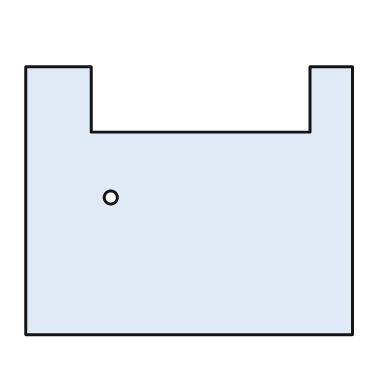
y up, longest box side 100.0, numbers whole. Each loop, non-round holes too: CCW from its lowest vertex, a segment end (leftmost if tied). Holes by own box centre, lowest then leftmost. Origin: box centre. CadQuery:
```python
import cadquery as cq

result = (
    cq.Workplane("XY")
    .moveTo(-50.0, -41.0)
    .lineTo(50.0, -41.0)
    .lineTo(50.0, 41.0)
    .lineTo(37.0, 41.0)
    .lineTo(37.0, 21.0)
    .lineTo(-30.0, 21.0)
    .lineTo(-30.0, 41.0)
    .lineTo(-50.0, 41.0)
    .close()
    .moveTo(-24.0, 1.0)
    .circle(2.0)
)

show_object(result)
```